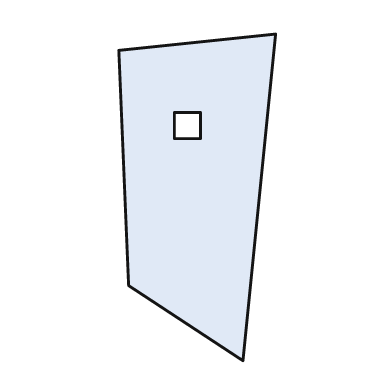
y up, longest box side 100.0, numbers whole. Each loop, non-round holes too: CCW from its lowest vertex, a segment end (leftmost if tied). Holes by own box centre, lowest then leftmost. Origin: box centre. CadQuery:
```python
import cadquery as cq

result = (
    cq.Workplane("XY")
    .moveTo(14.0, -50.0)
    .lineTo(24.0, 50.0)
    .lineTo(-24.0, 45.0)
    .lineTo(-21.0, -27.0)
    .close()
    .moveTo(-7.0, 18.0)
    .lineTo(1.0, 18.0)
    .lineTo(1.0, 26.0)
    .lineTo(-7.0, 26.0)
    .close()
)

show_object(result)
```